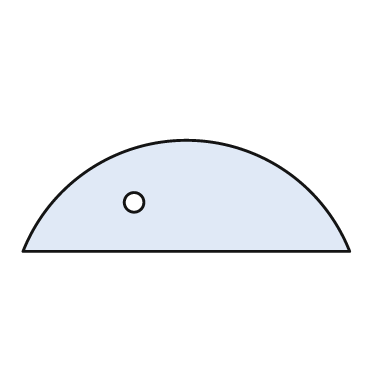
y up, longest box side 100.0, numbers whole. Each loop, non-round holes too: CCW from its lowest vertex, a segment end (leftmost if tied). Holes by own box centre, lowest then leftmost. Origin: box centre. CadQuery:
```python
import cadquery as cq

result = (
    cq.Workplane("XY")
    .moveTo(-50.0, -17.0)
    .lineTo(50.0, -17.0)
    .threePointArc((0.0, 17.0), (-50.0, -17.0))
    .close()
    .moveTo(-16.0, -2.0)
    .circle(3.0)
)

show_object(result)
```